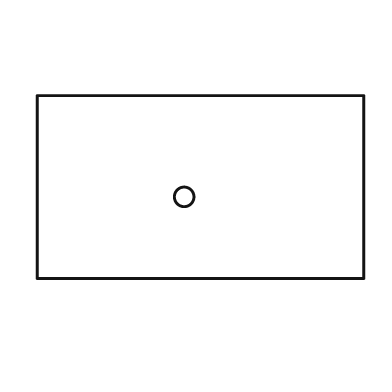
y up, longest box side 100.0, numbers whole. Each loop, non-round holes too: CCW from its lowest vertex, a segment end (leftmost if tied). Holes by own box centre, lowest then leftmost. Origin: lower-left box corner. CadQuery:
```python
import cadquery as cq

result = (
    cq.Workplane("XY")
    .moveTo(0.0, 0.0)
    .lineTo(100.0, 0.0)
    .lineTo(100.0, 56.0)
    .lineTo(0.0, 56.0)
    .close()
    .moveTo(45.0, 25.0)
    .circle(3.0)
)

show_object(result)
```